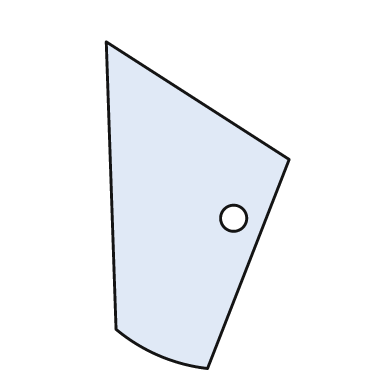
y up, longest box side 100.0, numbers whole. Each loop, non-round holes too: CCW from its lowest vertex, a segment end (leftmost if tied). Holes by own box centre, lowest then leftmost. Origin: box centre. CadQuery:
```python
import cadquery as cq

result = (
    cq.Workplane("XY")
    .moveTo(3.0, -50.0)
    .lineTo(28.0, 14.0)
    .lineTo(-28.0, 50.0)
    .lineTo(-25.0, -38.0)
    .threePointArc((-12.0, -46.0), (3.0, -50.0))
    .close()
    .moveTo(11.0, -4.0)
    .circle(4.0)
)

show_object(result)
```